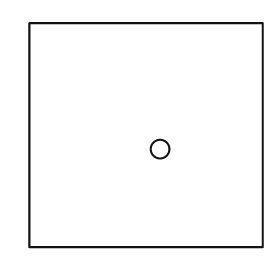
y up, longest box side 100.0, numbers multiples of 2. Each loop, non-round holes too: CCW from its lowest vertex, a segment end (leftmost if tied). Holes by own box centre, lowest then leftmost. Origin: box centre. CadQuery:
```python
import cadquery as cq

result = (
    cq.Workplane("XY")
    .moveTo(-50.0, -48.0)
    .lineTo(50.0, -48.0)
    .lineTo(50.0, 48.0)
    .lineTo(-50.0, 48.0)
    .close()
    .moveTo(6.0, -6.0)
    .circle(4.0)
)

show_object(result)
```